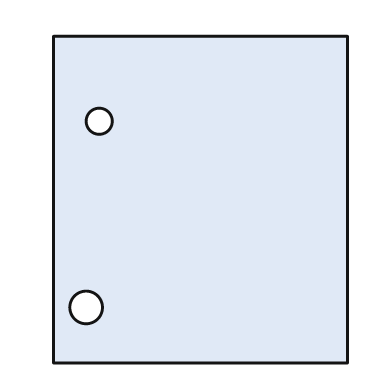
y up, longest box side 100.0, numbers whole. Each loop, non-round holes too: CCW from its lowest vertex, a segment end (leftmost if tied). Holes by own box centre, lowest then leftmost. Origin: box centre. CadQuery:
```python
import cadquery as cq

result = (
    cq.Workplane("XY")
    .moveTo(-45.0, -50.0)
    .lineTo(45.0, -50.0)
    .lineTo(45.0, 50.0)
    .lineTo(-45.0, 50.0)
    .close()
    .moveTo(-35.0, -33.0)
    .circle(5.0)
    .moveTo(-31.0, 24.0)
    .circle(4.0)
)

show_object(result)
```